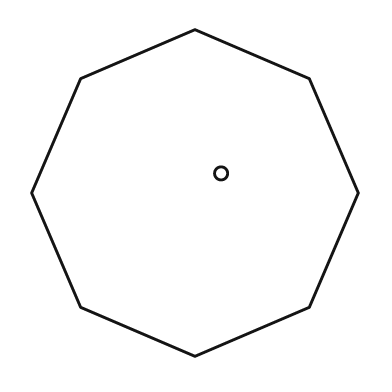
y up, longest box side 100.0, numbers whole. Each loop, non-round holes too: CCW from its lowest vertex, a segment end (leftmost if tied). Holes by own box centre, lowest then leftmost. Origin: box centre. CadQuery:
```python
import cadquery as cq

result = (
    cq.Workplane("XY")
    .moveTo(0.0, -50.0)
    .lineTo(35.0, -35.0)
    .lineTo(50.0, 0.0)
    .lineTo(35.0, 35.0)
    .lineTo(0.0, 50.0)
    .lineTo(-35.0, 35.0)
    .lineTo(-50.0, 0.0)
    .lineTo(-35.0, -35.0)
    .close()
    .moveTo(8.0, 6.0)
    .circle(2.0)
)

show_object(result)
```